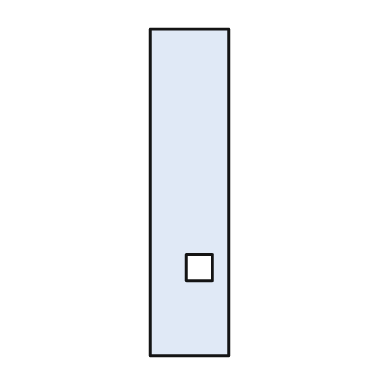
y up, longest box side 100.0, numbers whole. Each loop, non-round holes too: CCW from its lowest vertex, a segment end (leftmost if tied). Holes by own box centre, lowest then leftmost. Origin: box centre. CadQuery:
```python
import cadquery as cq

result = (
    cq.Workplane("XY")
    .moveTo(-12.0, -50.0)
    .lineTo(12.0, -50.0)
    .lineTo(12.0, 50.0)
    .lineTo(-12.0, 50.0)
    .close()
    .moveTo(-1.0, -27.0)
    .lineTo(7.0, -27.0)
    .lineTo(7.0, -19.0)
    .lineTo(-1.0, -19.0)
    .close()
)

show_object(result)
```